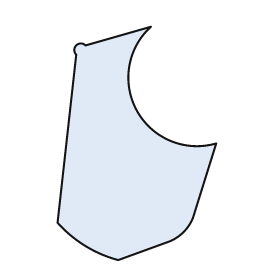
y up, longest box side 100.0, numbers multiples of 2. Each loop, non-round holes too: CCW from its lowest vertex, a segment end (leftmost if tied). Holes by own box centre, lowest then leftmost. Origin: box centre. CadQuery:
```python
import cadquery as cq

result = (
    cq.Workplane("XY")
    .moveTo(-8.0, -50.0)
    .lineTo(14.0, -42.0)
    .threePointArc((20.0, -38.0), (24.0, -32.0))
    .lineTo(34.0, 0.0)
    .threePointArc((0.0, 14.0), (6.0, 50.0))
    .lineTo(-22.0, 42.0)
    .threePointArc((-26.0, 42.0), (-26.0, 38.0))
    .lineTo(-34.0, -34.0)
    .threePointArc((-22.0, -44.0), (-8.0, -50.0))
    .close()
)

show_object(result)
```